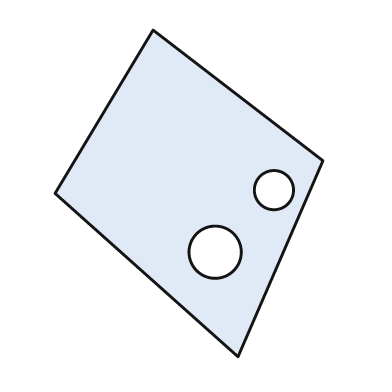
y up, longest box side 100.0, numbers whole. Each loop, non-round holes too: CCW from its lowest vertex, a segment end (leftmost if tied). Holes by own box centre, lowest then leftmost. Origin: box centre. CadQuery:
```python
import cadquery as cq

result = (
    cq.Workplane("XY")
    .moveTo(15.0, -50.0)
    .lineTo(41.0, 10.0)
    .lineTo(-11.0, 50.0)
    .lineTo(-41.0, 0.0)
    .close()
    .moveTo(8.0, -18.0)
    .circle(8.0)
    .moveTo(26.0, 1.0)
    .circle(6.0)
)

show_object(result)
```